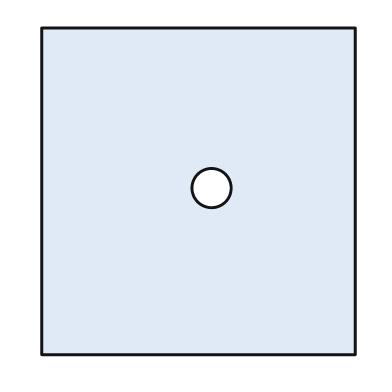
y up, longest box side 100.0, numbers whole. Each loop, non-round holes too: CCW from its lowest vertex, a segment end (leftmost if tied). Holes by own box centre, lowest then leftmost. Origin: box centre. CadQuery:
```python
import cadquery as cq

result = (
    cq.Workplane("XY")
    .moveTo(-48.0, -50.0)
    .lineTo(48.0, -50.0)
    .lineTo(48.0, 50.0)
    .lineTo(-48.0, 50.0)
    .close()
    .moveTo(4.0, 1.0)
    .circle(6.0)
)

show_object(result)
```